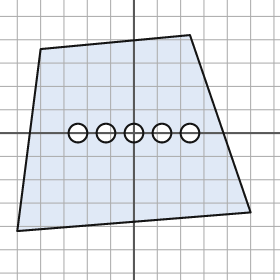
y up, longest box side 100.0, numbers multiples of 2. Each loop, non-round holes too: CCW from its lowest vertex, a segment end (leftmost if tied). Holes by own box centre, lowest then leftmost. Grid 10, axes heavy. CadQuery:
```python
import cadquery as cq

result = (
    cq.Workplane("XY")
    .moveTo(-50.0, -42.0)
    .lineTo(50.0, -34.0)
    .lineTo(24.0, 42.0)
    .lineTo(-40.0, 36.0)
    .close()
    .moveTo(-24.0, 0.0)
    .circle(4.0)
    .moveTo(-12.0, 0.0)
    .circle(4.0)
    .moveTo(0.0, 0.0)
    .circle(4.0)
    .moveTo(12.0, 0.0)
    .circle(4.0)
    .moveTo(24.0, 0.0)
    .circle(4.0)
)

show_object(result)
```